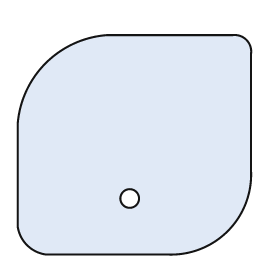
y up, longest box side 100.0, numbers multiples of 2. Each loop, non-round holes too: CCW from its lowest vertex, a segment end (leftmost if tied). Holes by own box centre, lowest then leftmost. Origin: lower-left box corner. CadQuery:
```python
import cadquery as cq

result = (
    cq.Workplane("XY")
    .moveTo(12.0, 0.0)
    .lineTo(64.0, 0.0)
    .threePointArc((90.0, 10.0), (100.0, 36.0))
    .lineTo(100.0, 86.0)
    .threePointArc((98.0, 92.0), (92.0, 94.0))
    .lineTo(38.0, 94.0)
    .threePointArc((12.0, 82.0), (0.0, 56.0))
    .lineTo(0.0, 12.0)
    .threePointArc((4.0, 4.0), (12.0, 0.0))
    .close()
    .moveTo(48.0, 24.0)
    .circle(4.0)
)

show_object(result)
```